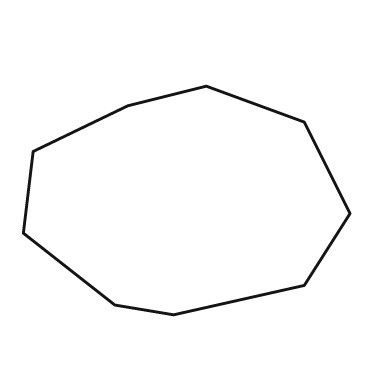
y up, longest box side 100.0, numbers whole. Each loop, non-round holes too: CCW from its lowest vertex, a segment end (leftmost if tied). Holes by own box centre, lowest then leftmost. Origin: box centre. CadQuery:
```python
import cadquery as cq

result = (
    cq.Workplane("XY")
    .moveTo(-4.0, -35.0)
    .lineTo(36.0, -26.0)
    .lineTo(50.0, -4.0)
    .lineTo(36.0, 24.0)
    .lineTo(6.0, 35.0)
    .lineTo(-18.0, 29.0)
    .lineTo(-47.0, 15.0)
    .lineTo(-50.0, -10.0)
    .lineTo(-22.0, -32.0)
    .close()
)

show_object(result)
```